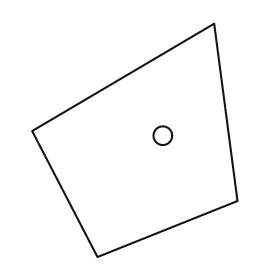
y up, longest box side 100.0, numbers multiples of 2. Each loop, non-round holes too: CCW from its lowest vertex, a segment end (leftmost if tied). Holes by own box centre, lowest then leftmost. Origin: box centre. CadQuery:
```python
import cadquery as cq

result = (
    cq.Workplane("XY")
    .moveTo(-16.0, -50.0)
    .lineTo(44.0, -26.0)
    .lineTo(34.0, 50.0)
    .lineTo(-44.0, 4.0)
    .close()
    .moveTo(12.0, 2.0)
    .circle(4.0)
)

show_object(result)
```